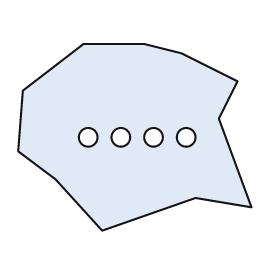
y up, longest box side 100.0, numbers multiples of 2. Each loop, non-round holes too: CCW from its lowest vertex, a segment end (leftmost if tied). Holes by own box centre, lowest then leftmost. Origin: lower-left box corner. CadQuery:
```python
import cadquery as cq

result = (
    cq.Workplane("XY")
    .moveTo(36.0, 0.0)
    .lineTo(76.0, 14.0)
    .lineTo(100.0, 10.0)
    .lineTo(86.0, 48.0)
    .lineTo(94.0, 64.0)
    .lineTo(70.0, 76.0)
    .lineTo(54.0, 80.0)
    .lineTo(28.0, 80.0)
    .lineTo(2.0, 60.0)
    .lineTo(0.0, 34.0)
    .lineTo(16.0, 22.0)
    .close()
    .moveTo(30.0, 40.0)
    .circle(4.0)
    .moveTo(44.0, 40.0)
    .circle(4.0)
    .moveTo(58.0, 40.0)
    .circle(4.0)
    .moveTo(72.0, 40.0)
    .circle(4.0)
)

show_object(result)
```